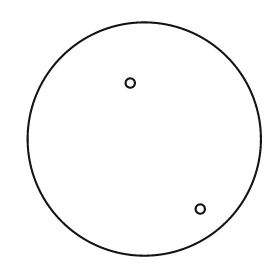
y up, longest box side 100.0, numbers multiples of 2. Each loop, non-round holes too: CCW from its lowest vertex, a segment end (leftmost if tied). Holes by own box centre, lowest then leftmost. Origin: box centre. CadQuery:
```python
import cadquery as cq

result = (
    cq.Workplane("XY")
    .moveTo(0.0, 0.0)
    .circle(50.0)
    .moveTo(24.0, -30.0)
    .circle(2.0)
    .moveTo(-6.0, 24.0)
    .circle(2.0)
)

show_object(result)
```